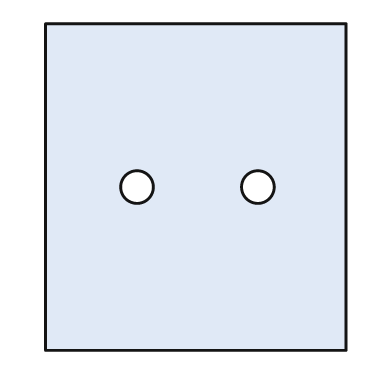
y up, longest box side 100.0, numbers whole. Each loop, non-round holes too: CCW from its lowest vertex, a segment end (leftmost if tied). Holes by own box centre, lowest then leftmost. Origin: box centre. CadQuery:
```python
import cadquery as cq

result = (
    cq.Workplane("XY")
    .moveTo(-46.0, -50.0)
    .lineTo(46.0, -50.0)
    .lineTo(46.0, 50.0)
    .lineTo(-46.0, 50.0)
    .close()
    .moveTo(-18.0, 0.0)
    .circle(5.0)
    .moveTo(19.0, 0.0)
    .circle(5.0)
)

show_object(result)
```